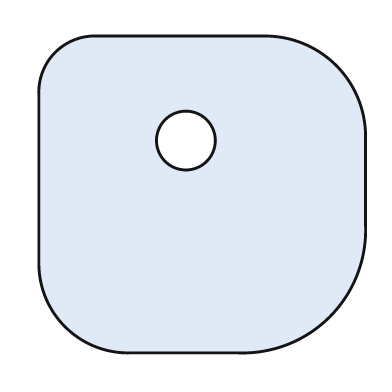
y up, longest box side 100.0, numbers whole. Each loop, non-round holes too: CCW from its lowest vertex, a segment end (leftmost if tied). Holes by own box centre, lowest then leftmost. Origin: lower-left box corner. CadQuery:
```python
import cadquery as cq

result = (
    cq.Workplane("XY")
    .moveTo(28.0, 0.0)
    .lineTo(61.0, 0.0)
    .threePointArc((89.0, 11.0), (100.0, 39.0))
    .lineTo(100.0, 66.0)
    .threePointArc((91.0, 88.0), (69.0, 97.0))
    .lineTo(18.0, 97.0)
    .threePointArc((5.0, 92.0), (0.0, 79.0))
    .lineTo(0.0, 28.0)
    .threePointArc((8.0, 8.0), (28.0, 0.0))
    .close()
    .moveTo(45.0, 65.0)
    .circle(9.0)
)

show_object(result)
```